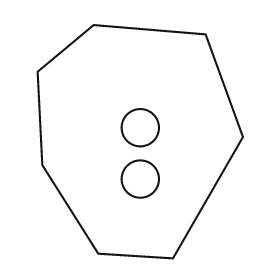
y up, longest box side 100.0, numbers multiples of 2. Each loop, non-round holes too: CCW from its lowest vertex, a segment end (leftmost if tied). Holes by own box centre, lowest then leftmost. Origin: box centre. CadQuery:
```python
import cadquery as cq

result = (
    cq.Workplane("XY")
    .moveTo(14.0, -50.0)
    .lineTo(44.0, 2.0)
    .lineTo(28.0, 46.0)
    .lineTo(-20.0, 50.0)
    .lineTo(-44.0, 30.0)
    .lineTo(-42.0, -10.0)
    .lineTo(-18.0, -48.0)
    .close()
    .moveTo(0.0, -16.0)
    .circle(8.0)
    .moveTo(0.0, 6.0)
    .circle(8.0)
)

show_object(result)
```